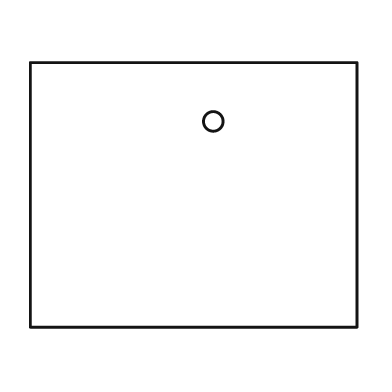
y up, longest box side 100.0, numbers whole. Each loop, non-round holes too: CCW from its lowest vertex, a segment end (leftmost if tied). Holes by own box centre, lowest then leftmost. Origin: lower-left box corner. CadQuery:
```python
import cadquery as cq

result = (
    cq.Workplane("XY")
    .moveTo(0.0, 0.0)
    .lineTo(100.0, 0.0)
    .lineTo(100.0, 81.0)
    .lineTo(0.0, 81.0)
    .close()
    .moveTo(56.0, 63.0)
    .circle(3.0)
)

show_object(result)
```